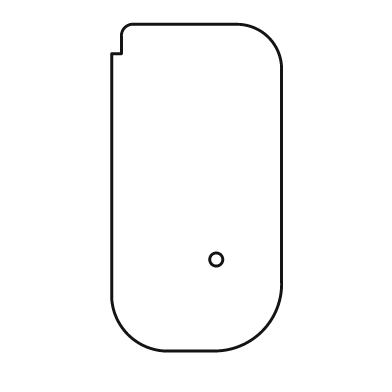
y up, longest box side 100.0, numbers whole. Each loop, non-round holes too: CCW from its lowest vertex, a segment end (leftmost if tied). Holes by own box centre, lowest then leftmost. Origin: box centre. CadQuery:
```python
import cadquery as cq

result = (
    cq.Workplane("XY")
    .moveTo(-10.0, -50.0)
    .lineTo(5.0, -50.0)
    .threePointArc((20.0, -44.0), (26.0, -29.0))
    .lineTo(26.0, 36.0)
    .threePointArc((22.0, 46.0), (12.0, 50.0))
    .lineTo(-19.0, 50.0)
    .threePointArc((-22.0, 49.0), (-23.0, 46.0))
    .lineTo(-23.0, 41.0)
    .lineTo(-26.0, 41.0)
    .lineTo(-26.0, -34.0)
    .threePointArc((-21.0, -45.0), (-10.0, -50.0))
    .close()
    .moveTo(6.0, -22.0)
    .circle(2.0)
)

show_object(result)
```